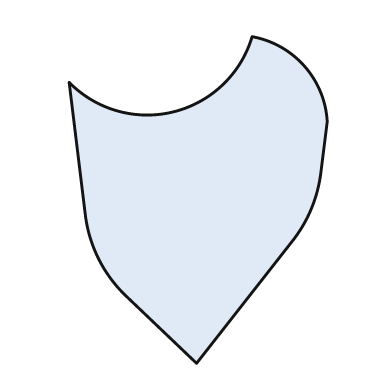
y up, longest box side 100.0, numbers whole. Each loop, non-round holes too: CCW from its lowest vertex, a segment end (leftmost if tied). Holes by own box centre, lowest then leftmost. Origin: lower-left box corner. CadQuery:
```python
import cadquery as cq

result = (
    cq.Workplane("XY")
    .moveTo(39.0, 0.0)
    .lineTo(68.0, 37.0)
    .threePointArc((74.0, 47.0), (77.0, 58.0))
    .lineTo(79.0, 74.0)
    .threePointArc((72.0, 91.0), (56.0, 100.0))
    .threePointArc((32.0, 77.0), (0.0, 86.0))
    .lineTo(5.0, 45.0)
    .threePointArc((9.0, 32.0), (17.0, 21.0))
    .close()
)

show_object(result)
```